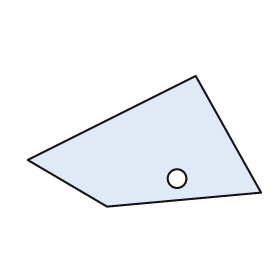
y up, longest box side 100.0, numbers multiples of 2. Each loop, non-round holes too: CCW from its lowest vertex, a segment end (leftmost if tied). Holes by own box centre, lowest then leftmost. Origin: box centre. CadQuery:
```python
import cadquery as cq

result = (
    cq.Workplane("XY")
    .moveTo(-16.0, -28.0)
    .lineTo(50.0, -22.0)
    .lineTo(22.0, 28.0)
    .lineTo(-50.0, -8.0)
    .close()
    .moveTo(14.0, -16.0)
    .circle(4.0)
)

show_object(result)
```